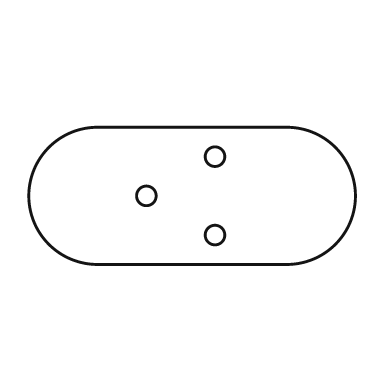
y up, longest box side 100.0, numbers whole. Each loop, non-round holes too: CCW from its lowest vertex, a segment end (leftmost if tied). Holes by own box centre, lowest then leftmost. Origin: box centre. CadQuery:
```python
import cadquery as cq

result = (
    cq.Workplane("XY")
    .moveTo(-29.0, -21.0)
    .lineTo(29.0, -21.0)
    .threePointArc((50.0, 0.0), (29.0, 21.0))
    .lineTo(-29.0, 21.0)
    .threePointArc((-50.0, 0.0), (-29.0, -21.0))
    .close()
    .moveTo(7.0, -12.0)
    .circle(3.0)
    .moveTo(-14.0, 0.0)
    .circle(3.0)
    .moveTo(7.0, 12.0)
    .circle(3.0)
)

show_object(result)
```